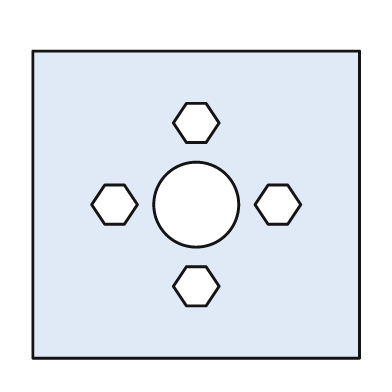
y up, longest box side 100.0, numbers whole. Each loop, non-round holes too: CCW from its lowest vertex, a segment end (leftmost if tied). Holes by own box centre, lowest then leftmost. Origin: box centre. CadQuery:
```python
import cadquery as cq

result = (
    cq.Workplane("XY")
    .moveTo(-50.0, -47.0)
    .lineTo(50.0, -47.0)
    .lineTo(50.0, 47.0)
    .lineTo(-50.0, 47.0)
    .close()
    .moveTo(-3.0, -31.0)
    .lineTo(3.0, -31.0)
    .lineTo(7.0, -25.0)
    .lineTo(3.0, -19.0)
    .lineTo(-3.0, -19.0)
    .lineTo(-7.0, -25.0)
    .close()
    .moveTo(-28.0, -6.0)
    .lineTo(-22.0, -6.0)
    .lineTo(-18.0, 0.0)
    .lineTo(-22.0, 6.0)
    .lineTo(-28.0, 6.0)
    .lineTo(-32.0, 0.0)
    .close()
    .moveTo(0.0, 0.0)
    .circle(13.0)
    .moveTo(22.0, -6.0)
    .lineTo(28.0, -6.0)
    .lineTo(32.0, 0.0)
    .lineTo(28.0, 6.0)
    .lineTo(22.0, 6.0)
    .lineTo(18.0, 0.0)
    .close()
    .moveTo(-3.0, 19.0)
    .lineTo(3.0, 19.0)
    .lineTo(7.0, 25.0)
    .lineTo(3.0, 31.0)
    .lineTo(-3.0, 31.0)
    .lineTo(-7.0, 25.0)
    .close()
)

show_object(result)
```